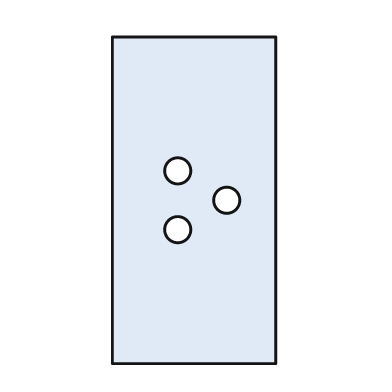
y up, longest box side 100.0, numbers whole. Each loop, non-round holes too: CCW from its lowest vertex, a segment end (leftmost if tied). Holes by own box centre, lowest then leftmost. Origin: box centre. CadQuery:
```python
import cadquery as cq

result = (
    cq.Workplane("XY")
    .moveTo(-25.0, -50.0)
    .lineTo(25.0, -50.0)
    .lineTo(25.0, 50.0)
    .lineTo(-25.0, 50.0)
    .close()
    .moveTo(-5.0, -9.0)
    .circle(4.0)
    .moveTo(10.0, 0.0)
    .circle(4.0)
    .moveTo(-5.0, 9.0)
    .circle(4.0)
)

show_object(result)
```